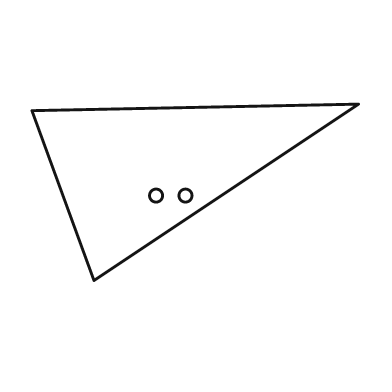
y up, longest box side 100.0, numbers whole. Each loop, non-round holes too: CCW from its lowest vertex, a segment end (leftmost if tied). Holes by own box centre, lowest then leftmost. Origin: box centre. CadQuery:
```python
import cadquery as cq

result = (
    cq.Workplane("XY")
    .moveTo(-31.0, -27.0)
    .lineTo(50.0, 27.0)
    .lineTo(-50.0, 25.0)
    .close()
    .moveTo(-12.0, -1.0)
    .circle(2.0)
    .moveTo(-3.0, -1.0)
    .circle(2.0)
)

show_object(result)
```